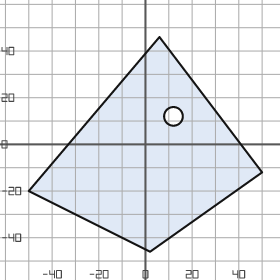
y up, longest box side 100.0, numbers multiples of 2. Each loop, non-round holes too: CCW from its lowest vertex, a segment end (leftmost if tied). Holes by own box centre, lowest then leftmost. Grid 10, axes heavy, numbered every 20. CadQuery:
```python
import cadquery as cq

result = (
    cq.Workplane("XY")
    .moveTo(2.0, -46.0)
    .lineTo(50.0, -12.0)
    .lineTo(6.0, 46.0)
    .lineTo(-50.0, -20.0)
    .close()
    .moveTo(12.0, 12.0)
    .circle(4.0)
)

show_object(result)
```